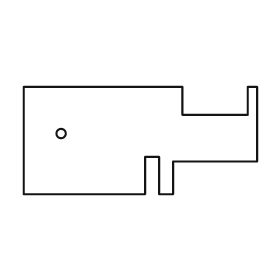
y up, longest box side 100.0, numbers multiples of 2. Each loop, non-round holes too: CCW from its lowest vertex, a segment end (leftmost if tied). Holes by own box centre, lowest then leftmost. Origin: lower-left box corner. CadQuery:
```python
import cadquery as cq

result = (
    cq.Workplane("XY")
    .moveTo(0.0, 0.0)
    .lineTo(52.0, 0.0)
    .lineTo(52.0, 16.0)
    .lineTo(58.0, 16.0)
    .lineTo(58.0, 0.0)
    .lineTo(64.0, 0.0)
    .lineTo(64.0, 14.0)
    .lineTo(100.0, 14.0)
    .lineTo(100.0, 46.0)
    .lineTo(96.0, 46.0)
    .lineTo(96.0, 34.0)
    .lineTo(68.0, 34.0)
    .lineTo(68.0, 46.0)
    .lineTo(0.0, 46.0)
    .close()
    .moveTo(16.0, 26.0)
    .circle(2.0)
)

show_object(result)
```